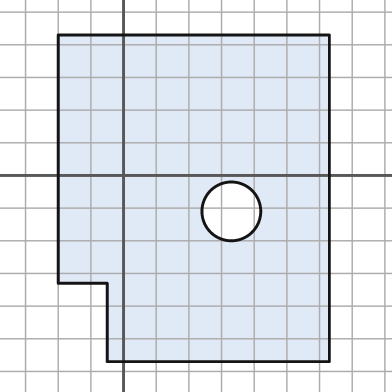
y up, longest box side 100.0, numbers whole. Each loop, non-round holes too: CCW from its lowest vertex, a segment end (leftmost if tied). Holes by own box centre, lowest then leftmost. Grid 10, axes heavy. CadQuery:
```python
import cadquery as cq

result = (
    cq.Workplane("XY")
    .moveTo(-5.0, -57.0)
    .lineTo(63.0, -57.0)
    .lineTo(63.0, 43.0)
    .lineTo(-20.0, 43.0)
    .lineTo(-20.0, -33.0)
    .lineTo(-5.0, -33.0)
    .close()
    .moveTo(33.0, -11.0)
    .circle(9.0)
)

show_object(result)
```